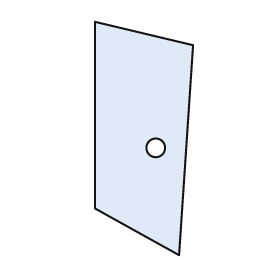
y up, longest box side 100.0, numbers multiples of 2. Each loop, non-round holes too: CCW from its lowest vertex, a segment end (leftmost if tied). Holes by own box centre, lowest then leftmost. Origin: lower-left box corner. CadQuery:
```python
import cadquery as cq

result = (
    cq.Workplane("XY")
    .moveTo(36.0, 0.0)
    .lineTo(42.0, 90.0)
    .lineTo(0.0, 100.0)
    .lineTo(0.0, 20.0)
    .close()
    .moveTo(26.0, 46.0)
    .circle(4.0)
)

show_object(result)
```